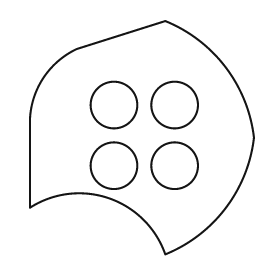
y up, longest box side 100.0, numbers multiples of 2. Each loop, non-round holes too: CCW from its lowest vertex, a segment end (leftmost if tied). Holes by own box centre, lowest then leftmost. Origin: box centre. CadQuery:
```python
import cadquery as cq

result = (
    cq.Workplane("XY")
    .moveTo(10.0, -50.0)
    .threePointArc((36.0, -30.0), (48.0, 0.0))
    .threePointArc((36.0, 30.0), (10.0, 50.0))
    .lineTo(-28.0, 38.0)
    .threePointArc((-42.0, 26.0), (-48.0, 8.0))
    .lineTo(-48.0, -30.0)
    .threePointArc((-14.0, -26.0), (10.0, -50.0))
    .close()
    .moveTo(-12.0, -12.0)
    .circle(10.0)
    .moveTo(14.0, -12.0)
    .circle(10.0)
    .moveTo(-12.0, 14.0)
    .circle(10.0)
    .moveTo(14.0, 14.0)
    .circle(10.0)
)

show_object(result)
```